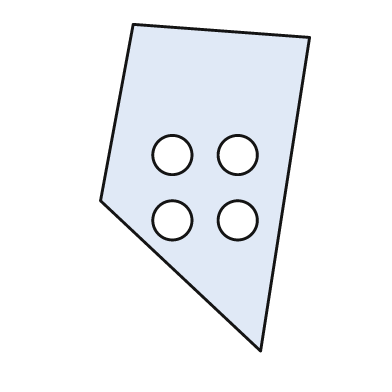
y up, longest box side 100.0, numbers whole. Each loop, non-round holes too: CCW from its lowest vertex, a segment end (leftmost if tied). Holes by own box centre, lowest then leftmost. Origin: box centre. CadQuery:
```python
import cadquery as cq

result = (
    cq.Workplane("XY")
    .moveTo(17.0, -50.0)
    .lineTo(32.0, 46.0)
    .lineTo(-22.0, 50.0)
    .lineTo(-32.0, -4.0)
    .close()
    .moveTo(-10.0, -10.0)
    .circle(6.0)
    .moveTo(10.0, -10.0)
    .circle(6.0)
    .moveTo(-10.0, 10.0)
    .circle(6.0)
    .moveTo(10.0, 10.0)
    .circle(6.0)
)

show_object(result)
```